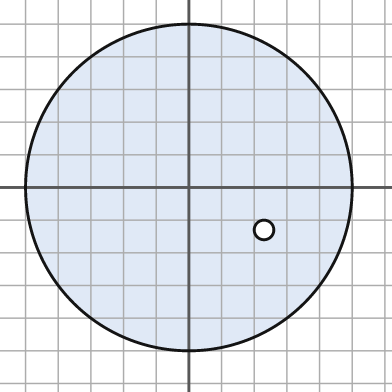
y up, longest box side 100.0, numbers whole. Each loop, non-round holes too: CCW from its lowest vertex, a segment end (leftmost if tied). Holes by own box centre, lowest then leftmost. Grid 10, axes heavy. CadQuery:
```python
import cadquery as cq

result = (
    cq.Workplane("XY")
    .moveTo(0.0, 0.0)
    .circle(50.0)
    .moveTo(23.0, -13.0)
    .circle(3.0)
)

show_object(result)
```